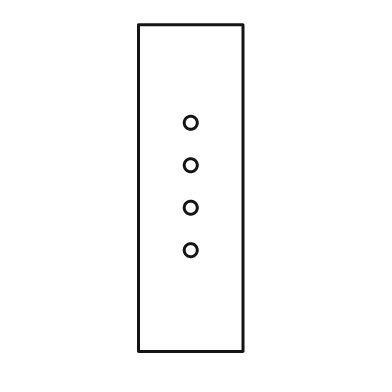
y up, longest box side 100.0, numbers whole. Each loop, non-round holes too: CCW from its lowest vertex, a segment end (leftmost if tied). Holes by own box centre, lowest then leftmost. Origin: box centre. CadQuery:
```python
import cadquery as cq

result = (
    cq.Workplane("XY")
    .moveTo(-16.0, -50.0)
    .lineTo(16.0, -50.0)
    .lineTo(16.0, 50.0)
    .lineTo(-16.0, 50.0)
    .close()
    .moveTo(0.0, -19.0)
    .circle(2.0)
    .moveTo(0.0, -6.0)
    .circle(2.0)
    .moveTo(0.0, 7.0)
    .circle(2.0)
    .moveTo(0.0, 20.0)
    .circle(2.0)
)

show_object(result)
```